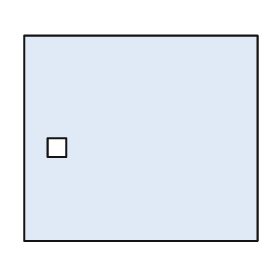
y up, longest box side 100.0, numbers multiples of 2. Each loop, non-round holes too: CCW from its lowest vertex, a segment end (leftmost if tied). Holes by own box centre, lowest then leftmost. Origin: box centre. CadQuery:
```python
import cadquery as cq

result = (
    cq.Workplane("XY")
    .moveTo(-50.0, -44.0)
    .lineTo(50.0, -44.0)
    .lineTo(50.0, 44.0)
    .lineTo(-50.0, 44.0)
    .close()
    .moveTo(-40.0, -8.0)
    .lineTo(-32.0, -8.0)
    .lineTo(-32.0, 0.0)
    .lineTo(-40.0, 0.0)
    .close()
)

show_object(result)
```